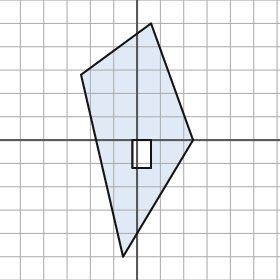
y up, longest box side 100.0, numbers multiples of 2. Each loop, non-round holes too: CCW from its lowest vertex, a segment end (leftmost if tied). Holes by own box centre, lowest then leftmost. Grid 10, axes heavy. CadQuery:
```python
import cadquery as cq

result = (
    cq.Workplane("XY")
    .moveTo(-6.0, -50.0)
    .lineTo(24.0, 0.0)
    .lineTo(6.0, 50.0)
    .lineTo(-24.0, 28.0)
    .close()
    .moveTo(-2.0, -12.0)
    .lineTo(6.0, -12.0)
    .lineTo(6.0, 0.0)
    .lineTo(-2.0, 0.0)
    .close()
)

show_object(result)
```